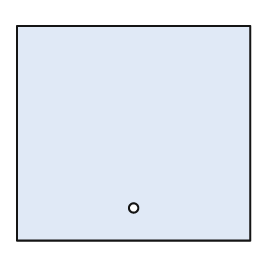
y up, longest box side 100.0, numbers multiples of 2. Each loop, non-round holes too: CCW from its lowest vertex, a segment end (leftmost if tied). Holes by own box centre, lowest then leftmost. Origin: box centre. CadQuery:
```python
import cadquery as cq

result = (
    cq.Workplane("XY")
    .moveTo(-50.0, -46.0)
    .lineTo(50.0, -46.0)
    .lineTo(50.0, 46.0)
    .lineTo(-50.0, 46.0)
    .close()
    .moveTo(0.0, -32.0)
    .circle(2.0)
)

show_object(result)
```